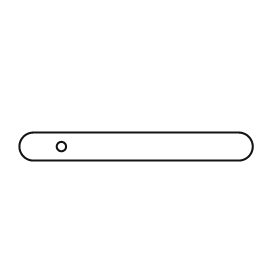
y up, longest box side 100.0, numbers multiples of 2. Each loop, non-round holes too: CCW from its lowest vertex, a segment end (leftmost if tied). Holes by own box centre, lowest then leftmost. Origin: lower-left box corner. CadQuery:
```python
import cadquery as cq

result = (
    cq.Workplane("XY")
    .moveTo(6.0, 0.0)
    .lineTo(94.0, 0.0)
    .threePointArc((100.0, 6.0), (94.0, 12.0))
    .lineTo(6.0, 12.0)
    .threePointArc((0.0, 6.0), (6.0, 0.0))
    .close()
    .moveTo(18.0, 6.0)
    .circle(2.0)
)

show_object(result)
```